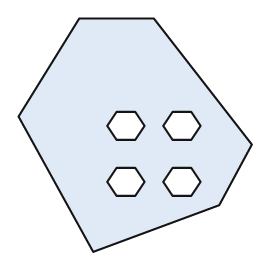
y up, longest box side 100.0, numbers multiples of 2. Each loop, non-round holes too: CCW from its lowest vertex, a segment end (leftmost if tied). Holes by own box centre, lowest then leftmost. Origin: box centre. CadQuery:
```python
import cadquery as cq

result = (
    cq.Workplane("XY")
    .moveTo(-18.0, -50.0)
    .lineTo(36.0, -30.0)
    .lineTo(50.0, -4.0)
    .lineTo(8.0, 50.0)
    .lineTo(-24.0, 50.0)
    .lineTo(-50.0, 8.0)
    .close()
    .moveTo(-8.0, -26.0)
    .lineTo(0.0, -26.0)
    .lineTo(4.0, -20.0)
    .lineTo(0.0, -14.0)
    .lineTo(-8.0, -14.0)
    .lineTo(-12.0, -20.0)
    .close()
    .moveTo(16.0, -26.0)
    .lineTo(24.0, -26.0)
    .lineTo(28.0, -20.0)
    .lineTo(24.0, -14.0)
    .lineTo(16.0, -14.0)
    .lineTo(12.0, -20.0)
    .close()
    .moveTo(-8.0, -2.0)
    .lineTo(0.0, -2.0)
    .lineTo(4.0, 4.0)
    .lineTo(0.0, 10.0)
    .lineTo(-8.0, 10.0)
    .lineTo(-12.0, 4.0)
    .close()
    .moveTo(16.0, -2.0)
    .lineTo(24.0, -2.0)
    .lineTo(28.0, 4.0)
    .lineTo(24.0, 10.0)
    .lineTo(16.0, 10.0)
    .lineTo(12.0, 4.0)
    .close()
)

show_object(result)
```